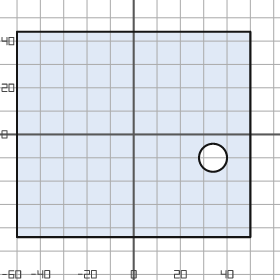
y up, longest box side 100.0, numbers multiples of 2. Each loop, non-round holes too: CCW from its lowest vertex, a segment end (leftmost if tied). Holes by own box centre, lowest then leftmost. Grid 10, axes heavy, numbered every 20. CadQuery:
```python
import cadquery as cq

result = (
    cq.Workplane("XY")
    .moveTo(-50.0, -44.0)
    .lineTo(50.0, -44.0)
    .lineTo(50.0, 44.0)
    .lineTo(-50.0, 44.0)
    .close()
    .moveTo(34.0, -10.0)
    .circle(6.0)
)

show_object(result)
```